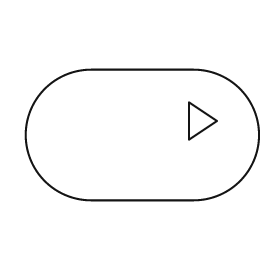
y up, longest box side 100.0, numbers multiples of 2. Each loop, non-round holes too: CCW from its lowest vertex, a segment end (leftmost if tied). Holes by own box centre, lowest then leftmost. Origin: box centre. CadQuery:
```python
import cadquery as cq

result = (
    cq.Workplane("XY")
    .moveTo(-22.0, -28.0)
    .lineTo(22.0, -28.0)
    .threePointArc((50.0, 0.0), (22.0, 28.0))
    .lineTo(-22.0, 28.0)
    .threePointArc((-50.0, 0.0), (-22.0, -28.0))
    .close()
    .moveTo(20.0, -2.0)
    .lineTo(32.0, 6.0)
    .lineTo(20.0, 14.0)
    .close()
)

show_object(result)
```